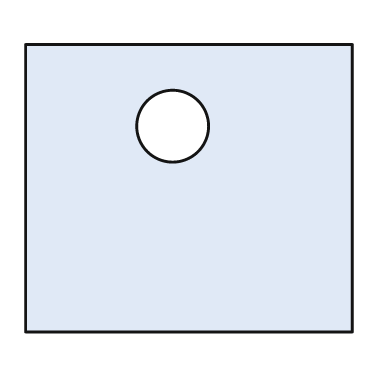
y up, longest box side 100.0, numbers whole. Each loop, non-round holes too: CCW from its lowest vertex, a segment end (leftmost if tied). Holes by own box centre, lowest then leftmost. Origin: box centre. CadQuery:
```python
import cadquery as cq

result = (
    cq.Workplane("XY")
    .moveTo(-50.0, -44.0)
    .lineTo(50.0, -44.0)
    .lineTo(50.0, 44.0)
    .lineTo(-50.0, 44.0)
    .close()
    .moveTo(-5.0, 19.0)
    .circle(11.0)
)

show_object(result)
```